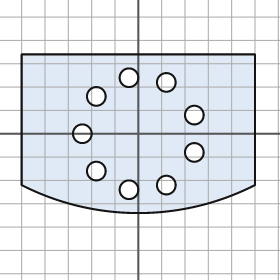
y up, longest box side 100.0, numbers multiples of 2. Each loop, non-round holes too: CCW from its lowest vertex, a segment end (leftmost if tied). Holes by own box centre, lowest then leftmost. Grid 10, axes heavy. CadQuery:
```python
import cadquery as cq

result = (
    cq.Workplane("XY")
    .moveTo(-50.0, -22.0)
    .threePointArc((0.0, -34.0), (50.0, -22.0))
    .lineTo(50.0, 34.0)
    .lineTo(-50.0, 34.0)
    .close()
    .moveTo(-4.0, -24.0)
    .circle(4.0)
    .moveTo(12.0, -22.0)
    .circle(4.0)
    .moveTo(-18.0, -16.0)
    .circle(4.0)
    .moveTo(24.0, -8.0)
    .circle(4.0)
    .moveTo(-24.0, 0.0)
    .circle(4.0)
    .moveTo(24.0, 8.0)
    .circle(4.0)
    .moveTo(-18.0, 16.0)
    .circle(4.0)
    .moveTo(12.0, 22.0)
    .circle(4.0)
    .moveTo(-4.0, 24.0)
    .circle(4.0)
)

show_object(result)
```